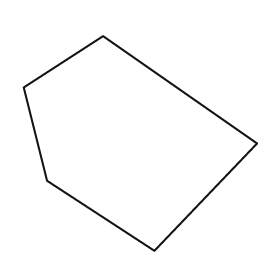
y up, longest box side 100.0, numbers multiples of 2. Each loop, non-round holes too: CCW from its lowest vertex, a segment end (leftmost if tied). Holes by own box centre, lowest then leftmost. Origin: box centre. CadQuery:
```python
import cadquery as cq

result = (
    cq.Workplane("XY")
    .moveTo(6.0, -46.0)
    .lineTo(50.0, 0.0)
    .lineTo(-16.0, 46.0)
    .lineTo(-50.0, 24.0)
    .lineTo(-40.0, -16.0)
    .close()
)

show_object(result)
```